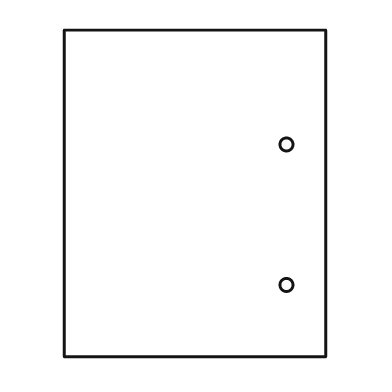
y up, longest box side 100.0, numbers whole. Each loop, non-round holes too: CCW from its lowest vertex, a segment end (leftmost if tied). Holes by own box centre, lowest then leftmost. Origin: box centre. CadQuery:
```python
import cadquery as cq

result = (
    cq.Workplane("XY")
    .moveTo(-40.0, -50.0)
    .lineTo(40.0, -50.0)
    .lineTo(40.0, 50.0)
    .lineTo(-40.0, 50.0)
    .close()
    .moveTo(28.0, -28.0)
    .circle(2.0)
    .moveTo(28.0, 15.0)
    .circle(2.0)
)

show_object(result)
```